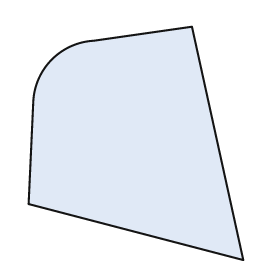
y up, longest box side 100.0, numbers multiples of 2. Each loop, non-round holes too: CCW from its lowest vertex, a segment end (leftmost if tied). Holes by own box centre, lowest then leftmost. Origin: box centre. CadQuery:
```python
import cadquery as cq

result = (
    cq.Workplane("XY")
    .moveTo(46.0, -50.0)
    .lineTo(24.0, 50.0)
    .lineTo(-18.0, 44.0)
    .threePointArc((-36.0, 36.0), (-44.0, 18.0))
    .lineTo(-46.0, -26.0)
    .close()
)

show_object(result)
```